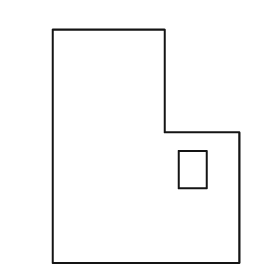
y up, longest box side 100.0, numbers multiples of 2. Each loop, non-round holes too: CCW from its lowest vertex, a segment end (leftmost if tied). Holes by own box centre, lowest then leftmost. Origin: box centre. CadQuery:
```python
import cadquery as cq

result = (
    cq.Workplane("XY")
    .moveTo(-40.0, -50.0)
    .lineTo(40.0, -50.0)
    .lineTo(40.0, 6.0)
    .lineTo(8.0, 6.0)
    .lineTo(8.0, 50.0)
    .lineTo(-40.0, 50.0)
    .close()
    .moveTo(14.0, -18.0)
    .lineTo(26.0, -18.0)
    .lineTo(26.0, -2.0)
    .lineTo(14.0, -2.0)
    .close()
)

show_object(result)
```